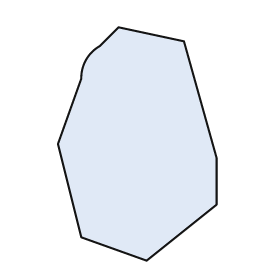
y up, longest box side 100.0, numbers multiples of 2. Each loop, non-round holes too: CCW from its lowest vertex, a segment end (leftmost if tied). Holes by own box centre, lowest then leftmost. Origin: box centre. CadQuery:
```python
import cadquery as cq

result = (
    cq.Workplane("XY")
    .moveTo(4.0, -50.0)
    .lineTo(34.0, -26.0)
    .lineTo(34.0, -6.0)
    .lineTo(20.0, 44.0)
    .lineTo(-8.0, 50.0)
    .lineTo(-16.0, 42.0)
    .threePointArc((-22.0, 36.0), (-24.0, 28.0))
    .lineTo(-34.0, 0.0)
    .lineTo(-24.0, -40.0)
    .close()
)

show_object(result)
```